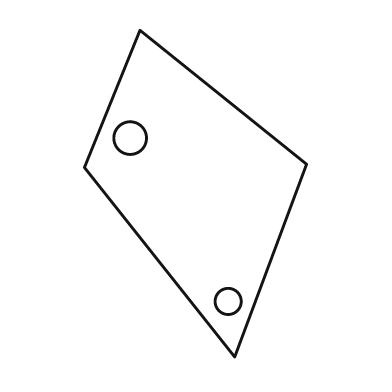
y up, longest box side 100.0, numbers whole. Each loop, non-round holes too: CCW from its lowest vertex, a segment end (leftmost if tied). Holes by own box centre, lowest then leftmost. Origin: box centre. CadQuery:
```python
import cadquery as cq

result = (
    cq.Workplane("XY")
    .moveTo(12.0, -50.0)
    .lineTo(34.0, 9.0)
    .lineTo(-17.0, 50.0)
    .lineTo(-34.0, 8.0)
    .close()
    .moveTo(10.0, -33.0)
    .circle(4.0)
    .moveTo(-20.0, 17.0)
    .circle(5.0)
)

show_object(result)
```